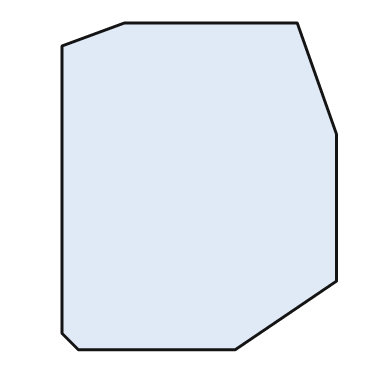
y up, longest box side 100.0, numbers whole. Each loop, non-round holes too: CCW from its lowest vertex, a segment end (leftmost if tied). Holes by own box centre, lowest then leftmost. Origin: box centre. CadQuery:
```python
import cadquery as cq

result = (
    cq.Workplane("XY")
    .moveTo(-37.0, -50.0)
    .lineTo(11.0, -50.0)
    .lineTo(42.0, -29.0)
    .lineTo(42.0, 16.0)
    .lineTo(30.0, 50.0)
    .lineTo(-23.0, 50.0)
    .lineTo(-42.0, 43.0)
    .lineTo(-42.0, -45.0)
    .close()
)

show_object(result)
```